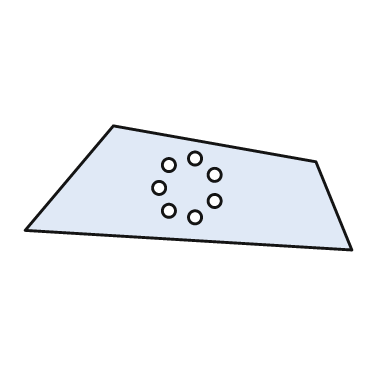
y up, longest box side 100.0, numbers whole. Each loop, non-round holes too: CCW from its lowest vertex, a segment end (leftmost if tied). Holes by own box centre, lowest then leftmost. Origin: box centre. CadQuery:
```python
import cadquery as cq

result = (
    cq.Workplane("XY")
    .moveTo(50.0, -19.0)
    .lineTo(39.0, 8.0)
    .lineTo(-23.0, 19.0)
    .lineTo(-50.0, -13.0)
    .close()
    .moveTo(2.0, -9.0)
    .circle(2.0)
    .moveTo(-6.0, -7.0)
    .circle(2.0)
    .moveTo(8.0, -4.0)
    .circle(2.0)
    .moveTo(-9.0, 0.0)
    .circle(2.0)
    .moveTo(8.0, 4.0)
    .circle(2.0)
    .moveTo(-6.0, 7.0)
    .circle(2.0)
    .moveTo(2.0, 9.0)
    .circle(2.0)
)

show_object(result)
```